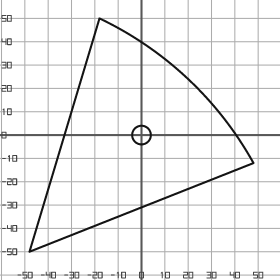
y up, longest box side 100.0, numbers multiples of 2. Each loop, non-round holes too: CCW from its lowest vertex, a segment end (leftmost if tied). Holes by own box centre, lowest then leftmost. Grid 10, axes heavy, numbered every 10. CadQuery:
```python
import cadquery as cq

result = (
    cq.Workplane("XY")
    .moveTo(-48.0, -50.0)
    .lineTo(48.0, -12.0)
    .threePointArc((20.0, 24.0), (-18.0, 50.0))
    .close()
    .moveTo(0.0, 0.0)
    .circle(4.0)
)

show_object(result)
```